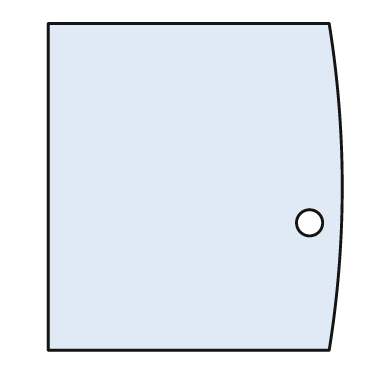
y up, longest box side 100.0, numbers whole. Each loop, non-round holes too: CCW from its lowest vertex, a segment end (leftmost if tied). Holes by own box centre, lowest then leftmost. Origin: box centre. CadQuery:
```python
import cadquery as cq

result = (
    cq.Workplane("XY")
    .moveTo(-45.0, -50.0)
    .lineTo(41.0, -50.0)
    .threePointArc((45.0, 0.0), (41.0, 50.0))
    .lineTo(-45.0, 50.0)
    .close()
    .moveTo(35.0, -11.0)
    .circle(4.0)
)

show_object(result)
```